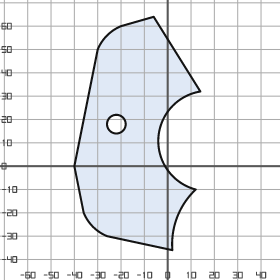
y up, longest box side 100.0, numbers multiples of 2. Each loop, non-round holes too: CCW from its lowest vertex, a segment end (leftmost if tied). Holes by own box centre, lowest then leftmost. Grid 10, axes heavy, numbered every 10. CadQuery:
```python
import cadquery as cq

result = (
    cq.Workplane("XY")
    .moveTo(2.0, -36.0)
    .threePointArc((4.0, -22.0), (12.0, -10.0))
    .threePointArc((-4.0, 12.0), (14.0, 32.0))
    .lineTo(-6.0, 64.0)
    .lineTo(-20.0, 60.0)
    .threePointArc((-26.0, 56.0), (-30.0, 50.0))
    .lineTo(-40.0, 0.0)
    .lineTo(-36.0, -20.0)
    .threePointArc((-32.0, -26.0), (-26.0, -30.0))
    .close()
    .moveTo(-22.0, 18.0)
    .circle(4.0)
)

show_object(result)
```